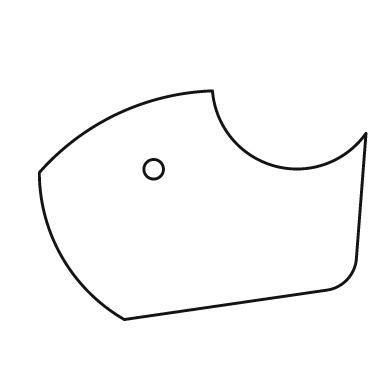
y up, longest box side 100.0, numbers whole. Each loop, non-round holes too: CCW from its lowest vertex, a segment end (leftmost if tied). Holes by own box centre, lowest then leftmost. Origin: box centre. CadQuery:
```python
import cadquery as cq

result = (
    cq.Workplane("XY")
    .moveTo(-24.0, -35.0)
    .lineTo(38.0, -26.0)
    .threePointArc((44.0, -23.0), (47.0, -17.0))
    .lineTo(50.0, 22.0)
    .threePointArc((22.0, 12.0), (3.0, 35.0))
    .threePointArc((-26.0, 28.0), (-50.0, 10.0))
    .threePointArc((-43.0, -16.0), (-24.0, -35.0))
    .close()
    .moveTo(-15.0, 11.0)
    .circle(3.0)
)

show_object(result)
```